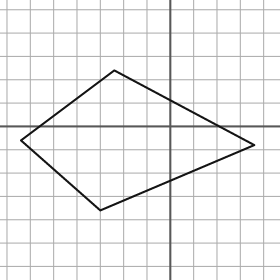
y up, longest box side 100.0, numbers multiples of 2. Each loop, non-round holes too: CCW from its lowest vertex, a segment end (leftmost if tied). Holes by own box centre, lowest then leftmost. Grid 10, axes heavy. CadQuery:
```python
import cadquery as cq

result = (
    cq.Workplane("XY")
    .moveTo(-30.0, -36.0)
    .lineTo(36.0, -8.0)
    .lineTo(-24.0, 24.0)
    .lineTo(-64.0, -6.0)
    .close()
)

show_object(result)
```